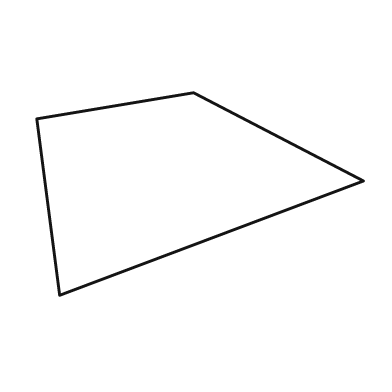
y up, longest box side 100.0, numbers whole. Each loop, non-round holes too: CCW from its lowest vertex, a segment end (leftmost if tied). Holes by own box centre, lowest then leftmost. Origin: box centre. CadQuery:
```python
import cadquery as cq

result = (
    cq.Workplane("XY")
    .moveTo(-43.0, -31.0)
    .lineTo(50.0, 4.0)
    .lineTo(-2.0, 31.0)
    .lineTo(-50.0, 23.0)
    .close()
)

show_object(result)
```